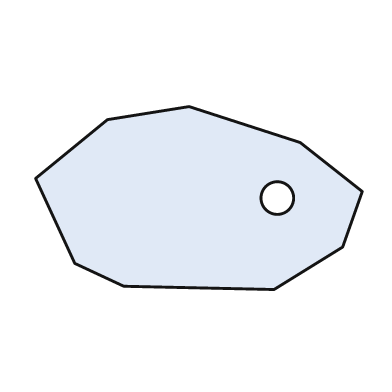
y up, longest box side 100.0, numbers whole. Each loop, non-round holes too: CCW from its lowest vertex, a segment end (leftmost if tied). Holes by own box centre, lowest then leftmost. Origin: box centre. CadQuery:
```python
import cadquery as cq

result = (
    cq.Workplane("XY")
    .moveTo(23.0, -28.0)
    .lineTo(44.0, -15.0)
    .lineTo(50.0, 2.0)
    .lineTo(31.0, 17.0)
    .lineTo(-3.0, 28.0)
    .lineTo(-28.0, 24.0)
    .lineTo(-50.0, 6.0)
    .lineTo(-38.0, -20.0)
    .lineTo(-23.0, -27.0)
    .close()
    .moveTo(24.0, 0.0)
    .circle(5.0)
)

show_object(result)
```